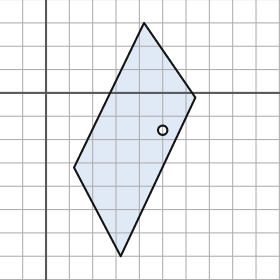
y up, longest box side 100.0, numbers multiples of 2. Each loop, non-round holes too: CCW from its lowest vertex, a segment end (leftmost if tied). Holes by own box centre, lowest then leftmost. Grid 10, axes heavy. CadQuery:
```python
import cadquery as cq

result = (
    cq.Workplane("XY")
    .moveTo(32.0, -70.0)
    .lineTo(64.0, -2.0)
    .lineTo(42.0, 30.0)
    .lineTo(12.0, -32.0)
    .close()
    .moveTo(50.0, -16.0)
    .circle(2.0)
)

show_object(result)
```